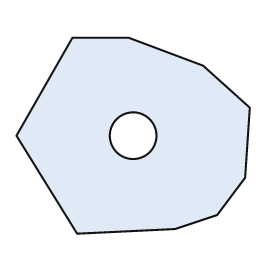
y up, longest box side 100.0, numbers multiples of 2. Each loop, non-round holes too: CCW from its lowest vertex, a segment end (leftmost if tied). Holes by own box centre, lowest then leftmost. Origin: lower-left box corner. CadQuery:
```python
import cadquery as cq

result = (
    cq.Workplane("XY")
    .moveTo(26.0, 0.0)
    .lineTo(68.0, 2.0)
    .lineTo(86.0, 8.0)
    .lineTo(98.0, 24.0)
    .lineTo(100.0, 54.0)
    .lineTo(80.0, 72.0)
    .lineTo(48.0, 84.0)
    .lineTo(24.0, 84.0)
    .lineTo(0.0, 42.0)
    .close()
    .moveTo(50.0, 42.0)
    .circle(10.0)
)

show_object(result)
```